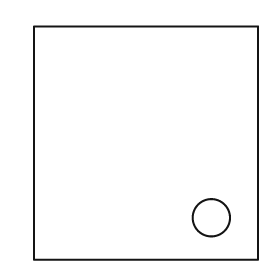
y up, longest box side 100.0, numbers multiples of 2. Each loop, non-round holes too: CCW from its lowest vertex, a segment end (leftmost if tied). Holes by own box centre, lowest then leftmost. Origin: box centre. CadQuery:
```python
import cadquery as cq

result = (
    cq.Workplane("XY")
    .moveTo(-48.0, -50.0)
    .lineTo(48.0, -50.0)
    .lineTo(48.0, 50.0)
    .lineTo(-48.0, 50.0)
    .close()
    .moveTo(28.0, -32.0)
    .circle(8.0)
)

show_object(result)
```